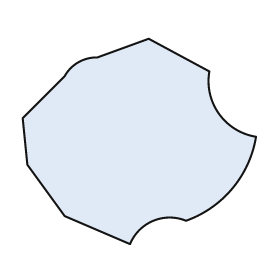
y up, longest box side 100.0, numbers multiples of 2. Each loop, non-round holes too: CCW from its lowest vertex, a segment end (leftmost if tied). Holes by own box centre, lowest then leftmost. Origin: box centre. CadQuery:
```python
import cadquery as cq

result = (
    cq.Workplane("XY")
    .moveTo(-4.0, -44.0)
    .threePointArc((6.0, -34.0), (20.0, -34.0))
    .threePointArc((40.0, -20.0), (50.0, 2.0))
    .threePointArc((34.0, 12.0), (30.0, 30.0))
    .lineTo(4.0, 44.0)
    .lineTo(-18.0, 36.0)
    .threePointArc((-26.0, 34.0), (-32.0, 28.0))
    .lineTo(-50.0, 10.0)
    .lineTo(-48.0, -10.0)
    .lineTo(-32.0, -32.0)
    .close()
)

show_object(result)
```